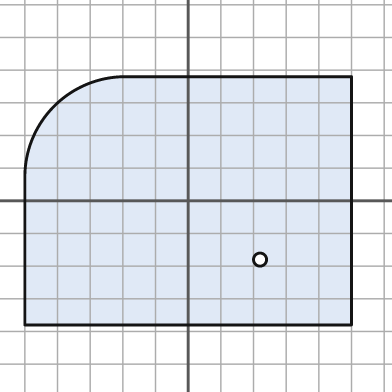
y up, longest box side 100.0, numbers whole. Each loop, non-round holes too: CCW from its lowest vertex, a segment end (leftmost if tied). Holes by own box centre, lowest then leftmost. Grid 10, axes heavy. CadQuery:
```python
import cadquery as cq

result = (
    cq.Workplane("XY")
    .moveTo(-50.0, -38.0)
    .lineTo(50.0, -38.0)
    .lineTo(50.0, 38.0)
    .lineTo(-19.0, 38.0)
    .threePointArc((-41.0, 29.0), (-50.0, 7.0))
    .close()
    .moveTo(22.0, -18.0)
    .circle(2.0)
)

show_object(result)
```